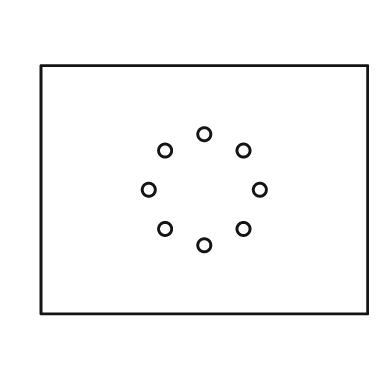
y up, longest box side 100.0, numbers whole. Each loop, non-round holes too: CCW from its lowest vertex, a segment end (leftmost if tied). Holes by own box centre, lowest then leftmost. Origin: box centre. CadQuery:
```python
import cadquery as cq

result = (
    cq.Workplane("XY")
    .moveTo(-50.0, -38.0)
    .lineTo(50.0, -38.0)
    .lineTo(50.0, 38.0)
    .lineTo(-50.0, 38.0)
    .close()
    .moveTo(0.0, -17.0)
    .circle(2.0)
    .moveTo(-12.0, -12.0)
    .circle(2.0)
    .moveTo(12.0, -12.0)
    .circle(2.0)
    .moveTo(-17.0, 0.0)
    .circle(2.0)
    .moveTo(17.0, 0.0)
    .circle(2.0)
    .moveTo(-12.0, 12.0)
    .circle(2.0)
    .moveTo(12.0, 12.0)
    .circle(2.0)
    .moveTo(0.0, 17.0)
    .circle(2.0)
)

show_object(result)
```